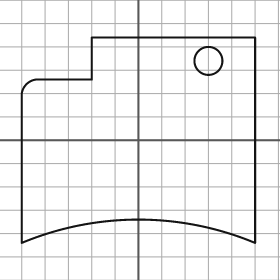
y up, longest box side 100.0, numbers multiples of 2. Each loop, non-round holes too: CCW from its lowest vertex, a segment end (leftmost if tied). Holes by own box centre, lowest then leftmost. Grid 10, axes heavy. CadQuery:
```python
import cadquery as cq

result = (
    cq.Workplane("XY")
    .moveTo(-50.0, -44.0)
    .threePointArc((0.0, -34.0), (50.0, -44.0))
    .lineTo(50.0, 44.0)
    .lineTo(-20.0, 44.0)
    .lineTo(-20.0, 26.0)
    .lineTo(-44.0, 26.0)
    .threePointArc((-48.0, 24.0), (-50.0, 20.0))
    .close()
    .moveTo(30.0, 34.0)
    .circle(6.0)
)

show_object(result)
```